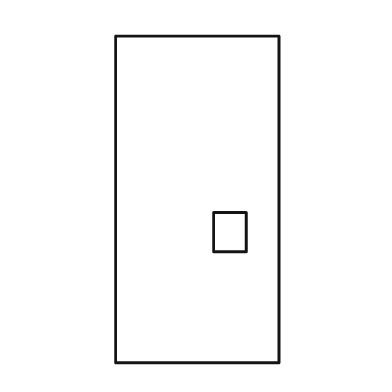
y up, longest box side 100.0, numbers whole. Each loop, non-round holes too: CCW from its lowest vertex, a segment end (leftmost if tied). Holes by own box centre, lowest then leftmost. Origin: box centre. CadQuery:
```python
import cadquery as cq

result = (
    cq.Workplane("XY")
    .moveTo(-25.0, -50.0)
    .lineTo(25.0, -50.0)
    .lineTo(25.0, 50.0)
    .lineTo(-25.0, 50.0)
    .close()
    .moveTo(5.0, -16.0)
    .lineTo(15.0, -16.0)
    .lineTo(15.0, -4.0)
    .lineTo(5.0, -4.0)
    .close()
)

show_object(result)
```